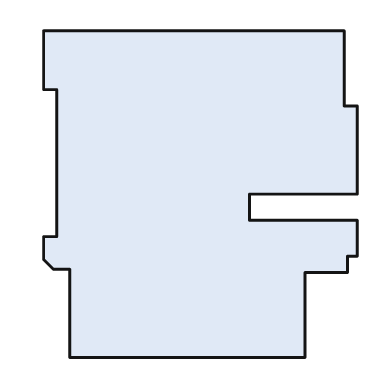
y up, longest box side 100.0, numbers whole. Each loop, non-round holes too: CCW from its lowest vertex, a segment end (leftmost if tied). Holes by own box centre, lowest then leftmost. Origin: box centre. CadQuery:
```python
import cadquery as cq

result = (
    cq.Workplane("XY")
    .moveTo(-40.0, -50.0)
    .lineTo(32.0, -50.0)
    .lineTo(32.0, -24.0)
    .lineTo(45.0, -24.0)
    .lineTo(45.0, -19.0)
    .lineTo(48.0, -19.0)
    .lineTo(48.0, -8.0)
    .lineTo(15.0, -8.0)
    .lineTo(15.0, 0.0)
    .lineTo(48.0, 0.0)
    .lineTo(48.0, 27.0)
    .lineTo(44.0, 27.0)
    .lineTo(44.0, 50.0)
    .lineTo(-48.0, 50.0)
    .lineTo(-48.0, 32.0)
    .lineTo(-44.0, 32.0)
    .lineTo(-44.0, -13.0)
    .lineTo(-48.0, -13.0)
    .lineTo(-48.0, -20.0)
    .lineTo(-45.0, -23.0)
    .lineTo(-40.0, -23.0)
    .close()
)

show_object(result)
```